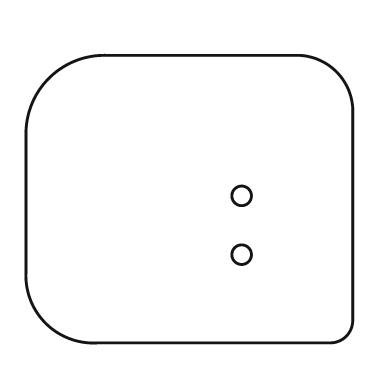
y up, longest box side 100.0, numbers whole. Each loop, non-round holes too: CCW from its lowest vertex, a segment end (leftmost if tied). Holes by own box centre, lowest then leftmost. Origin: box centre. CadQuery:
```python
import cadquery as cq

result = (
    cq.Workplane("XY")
    .moveTo(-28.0, -44.0)
    .lineTo(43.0, -44.0)
    .threePointArc((48.0, -42.0), (50.0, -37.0))
    .lineTo(50.0, 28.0)
    .threePointArc((45.0, 39.0), (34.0, 44.0))
    .lineTo(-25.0, 44.0)
    .threePointArc((-43.0, 37.0), (-50.0, 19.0))
    .lineTo(-50.0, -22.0)
    .threePointArc((-44.0, -38.0), (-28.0, -44.0))
    .close()
    .moveTo(16.0, -17.0)
    .circle(3.0)
    .moveTo(16.0, 1.0)
    .circle(3.0)
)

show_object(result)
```